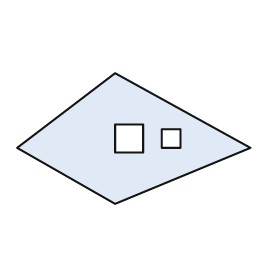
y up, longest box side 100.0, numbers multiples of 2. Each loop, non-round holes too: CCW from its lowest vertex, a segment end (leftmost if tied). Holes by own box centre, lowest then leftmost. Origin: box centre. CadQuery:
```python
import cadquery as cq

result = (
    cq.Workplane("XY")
    .moveTo(-8.0, -28.0)
    .lineTo(50.0, -4.0)
    .lineTo(-8.0, 28.0)
    .lineTo(-50.0, -4.0)
    .close()
    .moveTo(-8.0, -6.0)
    .lineTo(4.0, -6.0)
    .lineTo(4.0, 6.0)
    .lineTo(-8.0, 6.0)
    .close()
    .moveTo(12.0, -4.0)
    .lineTo(20.0, -4.0)
    .lineTo(20.0, 4.0)
    .lineTo(12.0, 4.0)
    .close()
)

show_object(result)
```